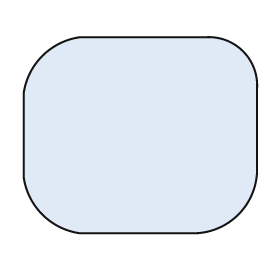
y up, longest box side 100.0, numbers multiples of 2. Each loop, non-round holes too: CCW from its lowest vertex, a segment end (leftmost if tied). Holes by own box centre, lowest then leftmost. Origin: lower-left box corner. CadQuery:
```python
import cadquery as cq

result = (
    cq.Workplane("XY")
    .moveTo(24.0, 0.0)
    .lineTo(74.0, 0.0)
    .threePointArc((92.0, 8.0), (100.0, 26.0))
    .lineTo(100.0, 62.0)
    .threePointArc((94.0, 78.0), (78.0, 84.0))
    .lineTo(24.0, 84.0)
    .threePointArc((8.0, 76.0), (0.0, 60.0))
    .lineTo(0.0, 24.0)
    .threePointArc((8.0, 8.0), (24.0, 0.0))
    .close()
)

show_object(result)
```